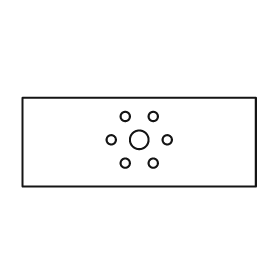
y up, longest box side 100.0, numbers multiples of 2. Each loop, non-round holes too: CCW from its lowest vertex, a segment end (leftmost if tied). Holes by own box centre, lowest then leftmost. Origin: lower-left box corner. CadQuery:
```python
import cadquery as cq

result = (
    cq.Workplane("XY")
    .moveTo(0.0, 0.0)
    .lineTo(100.0, 0.0)
    .lineTo(100.0, 38.0)
    .lineTo(0.0, 38.0)
    .close()
    .moveTo(44.0, 10.0)
    .circle(2.0)
    .moveTo(56.0, 10.0)
    .circle(2.0)
    .moveTo(38.0, 20.0)
    .circle(2.0)
    .moveTo(50.0, 20.0)
    .circle(4.0)
    .moveTo(62.0, 20.0)
    .circle(2.0)
    .moveTo(44.0, 30.0)
    .circle(2.0)
    .moveTo(56.0, 30.0)
    .circle(2.0)
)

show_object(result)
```